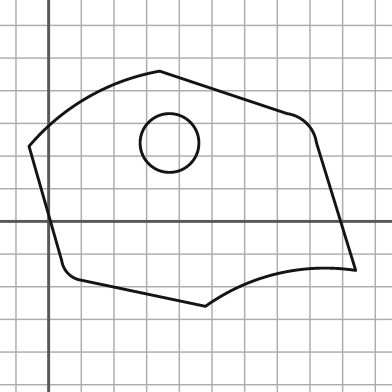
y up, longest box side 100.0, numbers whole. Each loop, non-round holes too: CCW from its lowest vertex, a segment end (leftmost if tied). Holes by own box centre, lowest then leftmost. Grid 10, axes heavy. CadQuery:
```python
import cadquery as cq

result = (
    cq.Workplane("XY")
    .moveTo(48.0, -26.0)
    .threePointArc((70.0, -16.0), (94.0, -15.0))
    .lineTo(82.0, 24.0)
    .threePointArc((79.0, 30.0), (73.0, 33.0))
    .lineTo(34.0, 46.0)
    .threePointArc((12.0, 38.0), (-6.0, 23.0))
    .lineTo(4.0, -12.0)
    .threePointArc((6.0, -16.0), (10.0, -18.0))
    .close()
    .moveTo(37.0, 24.0)
    .circle(9.0)
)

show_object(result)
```